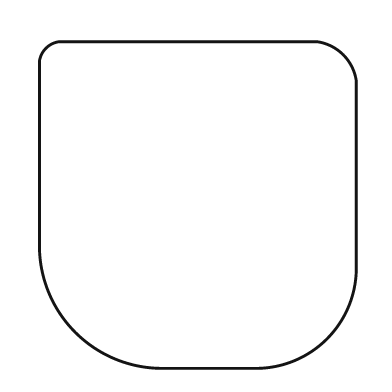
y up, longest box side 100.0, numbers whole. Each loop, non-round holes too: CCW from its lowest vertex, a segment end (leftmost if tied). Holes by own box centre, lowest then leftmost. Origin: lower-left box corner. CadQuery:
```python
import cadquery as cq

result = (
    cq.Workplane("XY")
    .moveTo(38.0, 0.0)
    .lineTo(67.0, 0.0)
    .threePointArc((88.0, 9.0), (97.0, 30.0))
    .lineTo(97.0, 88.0)
    .threePointArc((93.0, 96.0), (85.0, 100.0))
    .lineTo(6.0, 100.0)
    .threePointArc((2.0, 98.0), (0.0, 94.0))
    .lineTo(0.0, 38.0)
    .threePointArc((11.0, 11.0), (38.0, 0.0))
    .close()
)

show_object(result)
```